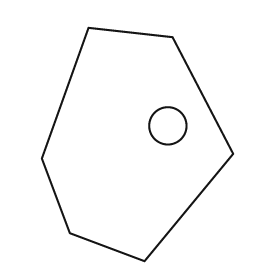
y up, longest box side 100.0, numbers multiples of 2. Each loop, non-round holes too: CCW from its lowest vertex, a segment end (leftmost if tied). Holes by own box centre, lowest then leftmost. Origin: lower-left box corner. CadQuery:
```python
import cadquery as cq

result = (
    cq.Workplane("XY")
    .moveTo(44.0, 0.0)
    .lineTo(82.0, 46.0)
    .lineTo(56.0, 96.0)
    .lineTo(20.0, 100.0)
    .lineTo(0.0, 44.0)
    .lineTo(12.0, 12.0)
    .close()
    .moveTo(54.0, 58.0)
    .circle(8.0)
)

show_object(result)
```